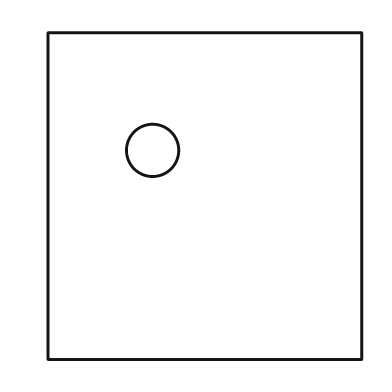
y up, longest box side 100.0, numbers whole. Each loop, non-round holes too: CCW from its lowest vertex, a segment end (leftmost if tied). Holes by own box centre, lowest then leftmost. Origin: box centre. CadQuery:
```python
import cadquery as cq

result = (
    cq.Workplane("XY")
    .moveTo(-48.0, -50.0)
    .lineTo(48.0, -50.0)
    .lineTo(48.0, 50.0)
    .lineTo(-48.0, 50.0)
    .close()
    .moveTo(-16.0, 14.0)
    .circle(8.0)
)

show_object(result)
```